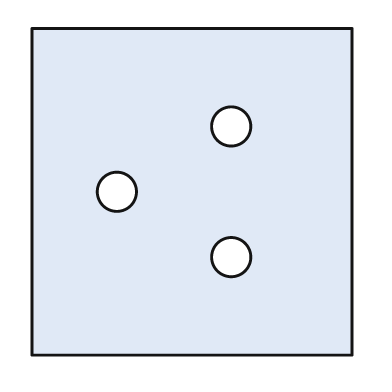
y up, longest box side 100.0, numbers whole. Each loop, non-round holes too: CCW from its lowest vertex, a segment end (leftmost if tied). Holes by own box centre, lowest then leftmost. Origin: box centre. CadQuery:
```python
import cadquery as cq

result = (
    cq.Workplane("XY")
    .moveTo(-49.0, -50.0)
    .lineTo(49.0, -50.0)
    .lineTo(49.0, 50.0)
    .lineTo(-49.0, 50.0)
    .close()
    .moveTo(12.0, -20.0)
    .circle(6.0)
    .moveTo(-23.0, 0.0)
    .circle(6.0)
    .moveTo(12.0, 20.0)
    .circle(6.0)
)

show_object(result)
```